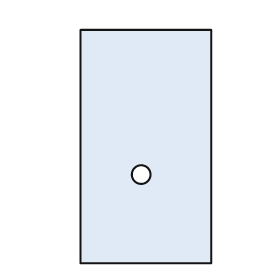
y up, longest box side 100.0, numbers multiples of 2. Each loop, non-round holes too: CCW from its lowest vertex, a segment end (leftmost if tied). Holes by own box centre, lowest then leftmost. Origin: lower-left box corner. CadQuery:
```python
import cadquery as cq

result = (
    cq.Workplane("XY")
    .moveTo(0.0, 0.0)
    .lineTo(56.0, 0.0)
    .lineTo(56.0, 100.0)
    .lineTo(0.0, 100.0)
    .close()
    .moveTo(26.0, 38.0)
    .circle(4.0)
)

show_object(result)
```